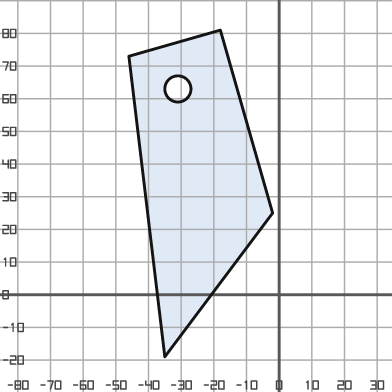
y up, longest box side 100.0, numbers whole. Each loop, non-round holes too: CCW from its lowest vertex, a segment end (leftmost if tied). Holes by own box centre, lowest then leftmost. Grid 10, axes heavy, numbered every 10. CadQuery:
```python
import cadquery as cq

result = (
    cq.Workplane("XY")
    .moveTo(-35.0, -19.0)
    .lineTo(-2.0, 25.0)
    .lineTo(-18.0, 81.0)
    .lineTo(-46.0, 73.0)
    .close()
    .moveTo(-31.0, 63.0)
    .circle(4.0)
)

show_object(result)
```